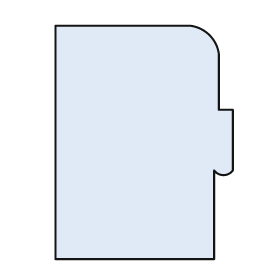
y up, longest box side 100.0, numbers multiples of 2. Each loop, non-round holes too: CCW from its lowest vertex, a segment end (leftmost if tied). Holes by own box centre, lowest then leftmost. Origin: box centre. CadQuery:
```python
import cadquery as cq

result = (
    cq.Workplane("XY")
    .moveTo(-38.0, -50.0)
    .lineTo(30.0, -50.0)
    .lineTo(30.0, -12.0)
    .threePointArc((34.0, -14.0), (38.0, -12.0))
    .lineTo(38.0, 14.0)
    .lineTo(32.0, 14.0)
    .lineTo(32.0, 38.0)
    .threePointArc((28.0, 46.0), (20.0, 50.0))
    .lineTo(-38.0, 50.0)
    .close()
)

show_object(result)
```